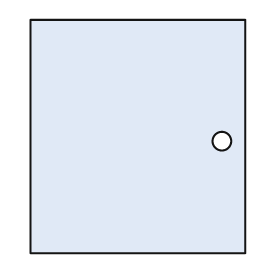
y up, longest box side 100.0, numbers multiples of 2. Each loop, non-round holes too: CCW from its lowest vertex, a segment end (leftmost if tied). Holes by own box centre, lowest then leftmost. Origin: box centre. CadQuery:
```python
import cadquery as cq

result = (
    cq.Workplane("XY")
    .moveTo(-46.0, -50.0)
    .lineTo(46.0, -50.0)
    .lineTo(46.0, 50.0)
    .lineTo(-46.0, 50.0)
    .close()
    .moveTo(36.0, -2.0)
    .circle(4.0)
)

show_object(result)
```